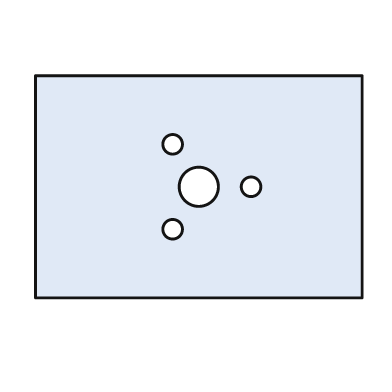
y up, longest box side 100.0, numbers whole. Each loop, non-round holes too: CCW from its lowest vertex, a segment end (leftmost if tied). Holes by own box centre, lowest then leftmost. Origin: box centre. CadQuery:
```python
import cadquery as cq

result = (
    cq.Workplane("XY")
    .moveTo(-50.0, -34.0)
    .lineTo(50.0, -34.0)
    .lineTo(50.0, 34.0)
    .lineTo(-50.0, 34.0)
    .close()
    .moveTo(-8.0, -13.0)
    .circle(3.0)
    .moveTo(0.0, 0.0)
    .circle(6.0)
    .moveTo(16.0, 0.0)
    .circle(3.0)
    .moveTo(-8.0, 13.0)
    .circle(3.0)
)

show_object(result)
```